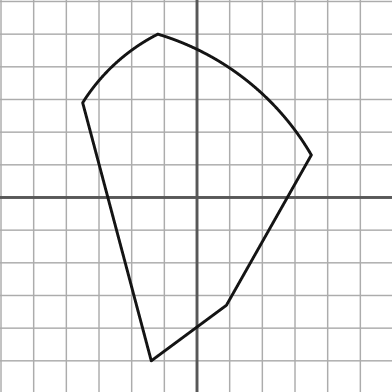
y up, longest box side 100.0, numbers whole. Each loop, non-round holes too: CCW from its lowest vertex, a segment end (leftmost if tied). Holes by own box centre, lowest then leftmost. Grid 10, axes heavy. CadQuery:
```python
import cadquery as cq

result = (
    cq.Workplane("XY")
    .moveTo(-14.0, -50.0)
    .lineTo(9.0, -33.0)
    .lineTo(35.0, 13.0)
    .threePointArc((15.0, 36.0), (-12.0, 50.0))
    .threePointArc((-25.0, 41.0), (-35.0, 29.0))
    .close()
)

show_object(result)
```